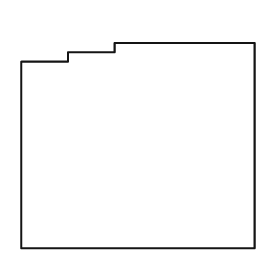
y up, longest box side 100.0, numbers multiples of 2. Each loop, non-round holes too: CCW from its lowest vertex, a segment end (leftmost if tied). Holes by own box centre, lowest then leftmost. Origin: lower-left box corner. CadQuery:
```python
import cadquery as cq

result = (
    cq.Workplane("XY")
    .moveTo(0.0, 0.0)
    .lineTo(100.0, 0.0)
    .lineTo(100.0, 88.0)
    .lineTo(40.0, 88.0)
    .lineTo(40.0, 84.0)
    .lineTo(20.0, 84.0)
    .lineTo(20.0, 80.0)
    .lineTo(0.0, 80.0)
    .close()
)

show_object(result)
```